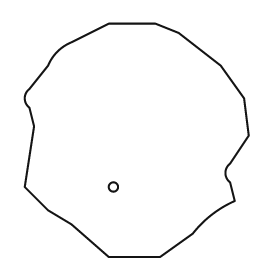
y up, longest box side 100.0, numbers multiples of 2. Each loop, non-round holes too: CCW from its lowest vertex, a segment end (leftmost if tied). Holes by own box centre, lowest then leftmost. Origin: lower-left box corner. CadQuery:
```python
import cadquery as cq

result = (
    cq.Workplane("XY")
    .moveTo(36.0, 0.0)
    .lineTo(58.0, 0.0)
    .lineTo(72.0, 10.0)
    .threePointArc((80.0, 18.0), (90.0, 24.0))
    .lineTo(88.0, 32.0)
    .threePointArc((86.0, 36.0), (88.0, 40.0))
    .lineTo(96.0, 52.0)
    .lineTo(94.0, 68.0)
    .lineTo(84.0, 82.0)
    .lineTo(66.0, 96.0)
    .lineTo(56.0, 100.0)
    .lineTo(36.0, 100.0)
    .lineTo(20.0, 92.0)
    .threePointArc((14.0, 88.0), (10.0, 82.0))
    .lineTo(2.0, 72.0)
    .threePointArc((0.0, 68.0), (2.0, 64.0))
    .lineTo(4.0, 56.0)
    .lineTo(0.0, 30.0)
    .lineTo(10.0, 20.0)
    .lineTo(20.0, 14.0)
    .close()
    .moveTo(38.0, 30.0)
    .circle(2.0)
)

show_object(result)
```